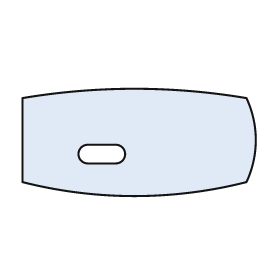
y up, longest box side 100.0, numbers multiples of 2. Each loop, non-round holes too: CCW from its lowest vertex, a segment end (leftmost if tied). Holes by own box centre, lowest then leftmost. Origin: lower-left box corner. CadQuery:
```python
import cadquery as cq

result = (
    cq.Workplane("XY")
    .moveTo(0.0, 6.0)
    .threePointArc((48.0, 0.0), (96.0, 6.0))
    .threePointArc((100.0, 24.0), (96.0, 42.0))
    .threePointArc((48.0, 46.0), (0.0, 42.0))
    .close()
    .moveTo(28.0, 14.0)
    .lineTo(40.0, 14.0)
    .threePointArc((44.0, 18.0), (40.0, 22.0))
    .lineTo(28.0, 22.0)
    .threePointArc((24.0, 18.0), (28.0, 14.0))
    .close()
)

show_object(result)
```